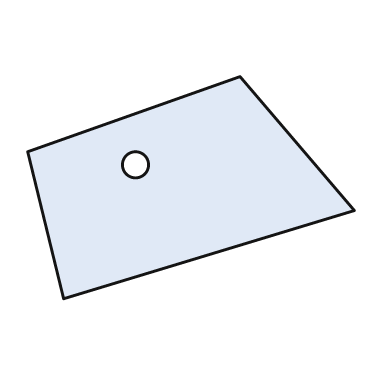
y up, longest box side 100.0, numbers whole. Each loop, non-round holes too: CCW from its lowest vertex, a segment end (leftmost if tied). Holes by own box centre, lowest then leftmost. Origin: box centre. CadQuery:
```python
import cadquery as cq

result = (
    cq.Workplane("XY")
    .moveTo(-39.0, -34.0)
    .lineTo(50.0, -7.0)
    .lineTo(15.0, 34.0)
    .lineTo(-50.0, 11.0)
    .close()
    .moveTo(-17.0, 7.0)
    .circle(4.0)
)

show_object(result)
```